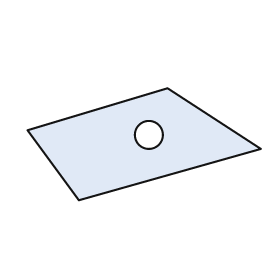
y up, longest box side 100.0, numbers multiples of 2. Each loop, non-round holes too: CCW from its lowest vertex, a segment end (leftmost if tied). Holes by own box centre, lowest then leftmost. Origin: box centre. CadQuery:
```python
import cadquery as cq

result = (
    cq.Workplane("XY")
    .moveTo(-28.0, -24.0)
    .lineTo(50.0, -2.0)
    .lineTo(10.0, 24.0)
    .lineTo(-50.0, 6.0)
    .close()
    .moveTo(2.0, 4.0)
    .circle(6.0)
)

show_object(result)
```